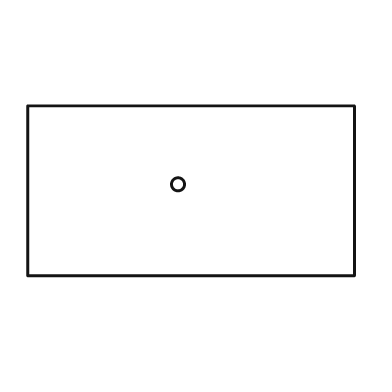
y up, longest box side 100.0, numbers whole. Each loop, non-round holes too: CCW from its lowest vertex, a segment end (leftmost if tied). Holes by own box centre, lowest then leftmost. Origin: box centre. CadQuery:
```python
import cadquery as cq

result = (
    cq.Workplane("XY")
    .moveTo(-50.0, -26.0)
    .lineTo(50.0, -26.0)
    .lineTo(50.0, 26.0)
    .lineTo(-50.0, 26.0)
    .close()
    .moveTo(-4.0, 2.0)
    .circle(2.0)
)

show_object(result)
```